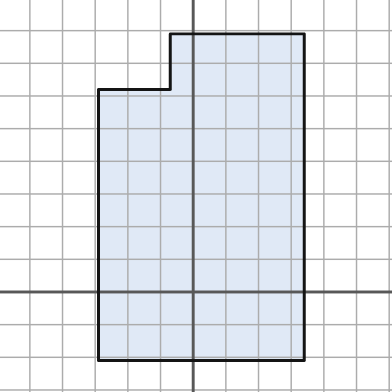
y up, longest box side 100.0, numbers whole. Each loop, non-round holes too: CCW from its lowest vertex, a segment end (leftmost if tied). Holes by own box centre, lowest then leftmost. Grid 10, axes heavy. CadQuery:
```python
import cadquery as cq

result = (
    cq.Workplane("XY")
    .moveTo(-29.0, -21.0)
    .lineTo(34.0, -21.0)
    .lineTo(34.0, 79.0)
    .lineTo(-7.0, 79.0)
    .lineTo(-7.0, 62.0)
    .lineTo(-29.0, 62.0)
    .close()
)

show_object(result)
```